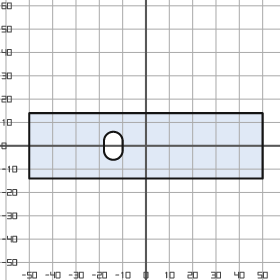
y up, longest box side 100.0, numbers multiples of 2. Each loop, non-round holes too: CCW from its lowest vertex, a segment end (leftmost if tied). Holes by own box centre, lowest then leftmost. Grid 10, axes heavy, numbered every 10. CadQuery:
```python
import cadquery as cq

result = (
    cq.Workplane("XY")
    .moveTo(-50.0, -14.0)
    .lineTo(50.0, -14.0)
    .lineTo(50.0, 14.0)
    .lineTo(-50.0, 14.0)
    .close()
    .moveTo(-18.0, -2.0)
    .threePointArc((-14.0, -6.0), (-10.0, -2.0))
    .lineTo(-10.0, 2.0)
    .threePointArc((-14.0, 6.0), (-18.0, 2.0))
    .close()
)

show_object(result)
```